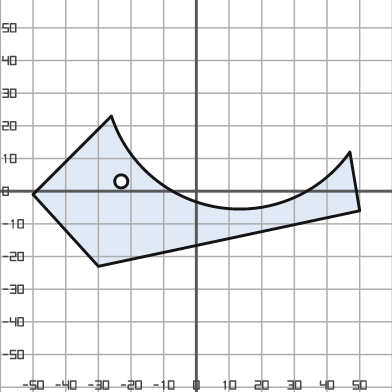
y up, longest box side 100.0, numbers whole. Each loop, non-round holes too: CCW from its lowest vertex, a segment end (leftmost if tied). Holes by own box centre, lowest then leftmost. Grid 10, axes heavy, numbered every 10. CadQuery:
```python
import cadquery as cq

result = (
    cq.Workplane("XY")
    .moveTo(-30.0, -23.0)
    .lineTo(50.0, -6.0)
    .lineTo(47.0, 12.0)
    .threePointArc((7.0, -5.0), (-26.0, 23.0))
    .lineTo(-50.0, -1.0)
    .close()
    .moveTo(-23.0, 3.0)
    .circle(2.0)
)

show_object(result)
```